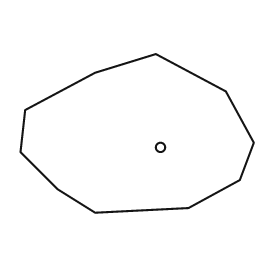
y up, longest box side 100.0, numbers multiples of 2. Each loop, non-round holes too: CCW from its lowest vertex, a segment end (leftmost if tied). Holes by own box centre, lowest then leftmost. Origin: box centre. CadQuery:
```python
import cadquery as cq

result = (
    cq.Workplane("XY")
    .moveTo(-18.0, -34.0)
    .lineTo(22.0, -32.0)
    .lineTo(44.0, -20.0)
    .lineTo(50.0, -4.0)
    .lineTo(38.0, 18.0)
    .lineTo(8.0, 34.0)
    .lineTo(-18.0, 26.0)
    .lineTo(-48.0, 10.0)
    .lineTo(-50.0, -8.0)
    .lineTo(-34.0, -24.0)
    .close()
    .moveTo(10.0, -6.0)
    .circle(2.0)
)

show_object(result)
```